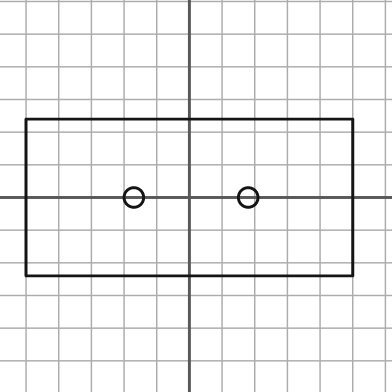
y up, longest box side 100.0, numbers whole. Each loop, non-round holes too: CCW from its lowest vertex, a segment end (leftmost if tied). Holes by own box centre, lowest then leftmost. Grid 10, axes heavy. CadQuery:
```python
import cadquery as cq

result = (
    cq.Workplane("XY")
    .moveTo(-50.0, -24.0)
    .lineTo(50.0, -24.0)
    .lineTo(50.0, 24.0)
    .lineTo(-50.0, 24.0)
    .close()
    .moveTo(-17.0, 0.0)
    .circle(3.0)
    .moveTo(18.0, 0.0)
    .circle(3.0)
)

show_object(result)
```